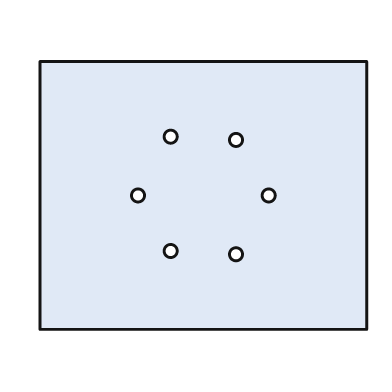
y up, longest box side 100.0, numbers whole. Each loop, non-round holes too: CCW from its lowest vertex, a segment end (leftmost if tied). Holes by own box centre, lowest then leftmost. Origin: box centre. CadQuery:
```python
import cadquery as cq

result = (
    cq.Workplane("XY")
    .moveTo(-50.0, -41.0)
    .lineTo(50.0, -41.0)
    .lineTo(50.0, 41.0)
    .lineTo(-50.0, 41.0)
    .close()
    .moveTo(10.0, -18.0)
    .circle(2.0)
    .moveTo(-10.0, -17.0)
    .circle(2.0)
    .moveTo(-20.0, 0.0)
    .circle(2.0)
    .moveTo(20.0, 0.0)
    .circle(2.0)
    .moveTo(10.0, 17.0)
    .circle(2.0)
    .moveTo(-10.0, 18.0)
    .circle(2.0)
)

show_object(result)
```